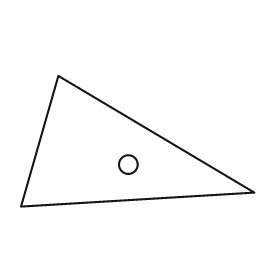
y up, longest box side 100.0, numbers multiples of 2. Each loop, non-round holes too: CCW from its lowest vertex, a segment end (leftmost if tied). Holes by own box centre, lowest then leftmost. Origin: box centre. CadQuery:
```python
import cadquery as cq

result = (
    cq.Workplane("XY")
    .moveTo(-50.0, -28.0)
    .lineTo(50.0, -22.0)
    .lineTo(-34.0, 28.0)
    .close()
    .moveTo(-4.0, -10.0)
    .circle(4.0)
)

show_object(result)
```